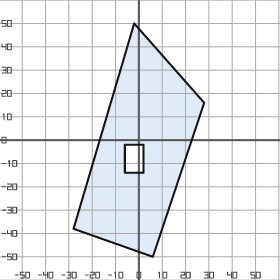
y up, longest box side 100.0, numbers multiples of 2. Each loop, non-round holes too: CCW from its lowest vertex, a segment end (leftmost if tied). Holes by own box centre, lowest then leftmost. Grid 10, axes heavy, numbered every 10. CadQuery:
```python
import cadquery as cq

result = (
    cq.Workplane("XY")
    .moveTo(6.0, -50.0)
    .lineTo(28.0, 16.0)
    .lineTo(-2.0, 50.0)
    .lineTo(-28.0, -38.0)
    .close()
    .moveTo(-6.0, -14.0)
    .lineTo(2.0, -14.0)
    .lineTo(2.0, -2.0)
    .lineTo(-6.0, -2.0)
    .close()
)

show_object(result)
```